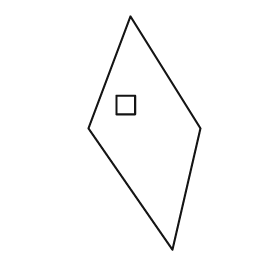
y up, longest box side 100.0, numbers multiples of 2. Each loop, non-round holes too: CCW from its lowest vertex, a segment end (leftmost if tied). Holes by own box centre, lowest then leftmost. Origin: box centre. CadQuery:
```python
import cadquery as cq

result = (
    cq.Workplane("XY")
    .moveTo(12.0, -50.0)
    .lineTo(24.0, 2.0)
    .lineTo(-6.0, 50.0)
    .lineTo(-24.0, 2.0)
    .close()
    .moveTo(-12.0, 8.0)
    .lineTo(-4.0, 8.0)
    .lineTo(-4.0, 16.0)
    .lineTo(-12.0, 16.0)
    .close()
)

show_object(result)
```